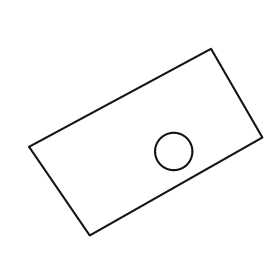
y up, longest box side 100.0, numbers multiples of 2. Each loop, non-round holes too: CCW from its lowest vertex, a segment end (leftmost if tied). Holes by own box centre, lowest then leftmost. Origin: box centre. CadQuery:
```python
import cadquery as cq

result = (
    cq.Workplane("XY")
    .moveTo(-24.0, -40.0)
    .lineTo(50.0, 2.0)
    .lineTo(28.0, 40.0)
    .lineTo(-50.0, -2.0)
    .close()
    .moveTo(12.0, -4.0)
    .circle(8.0)
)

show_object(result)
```